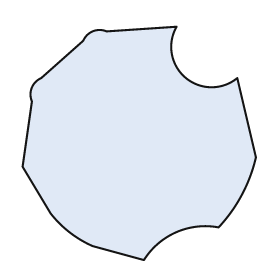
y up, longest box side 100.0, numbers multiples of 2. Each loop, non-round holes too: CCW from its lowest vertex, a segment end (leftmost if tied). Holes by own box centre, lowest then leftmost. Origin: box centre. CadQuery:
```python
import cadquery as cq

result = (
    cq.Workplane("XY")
    .moveTo(2.0, -50.0)
    .threePointArc((16.0, -38.0), (34.0, -36.0))
    .threePointArc((44.0, -22.0), (50.0, -6.0))
    .lineTo(42.0, 28.0)
    .threePointArc((20.0, 28.0), (16.0, 50.0))
    .lineTo(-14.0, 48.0)
    .threePointArc((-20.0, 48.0), (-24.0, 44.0))
    .lineTo(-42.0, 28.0)
    .threePointArc((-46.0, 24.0), (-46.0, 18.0))
    .lineTo(-50.0, -10.0)
    .lineTo(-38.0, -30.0)
    .threePointArc((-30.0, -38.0), (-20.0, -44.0))
    .close()
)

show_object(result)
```